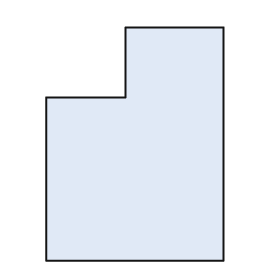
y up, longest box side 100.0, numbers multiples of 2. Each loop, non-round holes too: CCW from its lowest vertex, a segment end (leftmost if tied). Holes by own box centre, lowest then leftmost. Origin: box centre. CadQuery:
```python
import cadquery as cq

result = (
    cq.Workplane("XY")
    .moveTo(-38.0, -50.0)
    .lineTo(38.0, -50.0)
    .lineTo(38.0, 50.0)
    .lineTo(-4.0, 50.0)
    .lineTo(-4.0, 20.0)
    .lineTo(-38.0, 20.0)
    .close()
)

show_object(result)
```